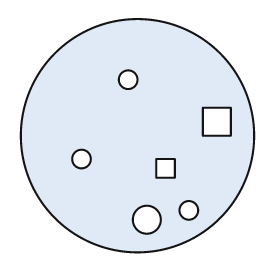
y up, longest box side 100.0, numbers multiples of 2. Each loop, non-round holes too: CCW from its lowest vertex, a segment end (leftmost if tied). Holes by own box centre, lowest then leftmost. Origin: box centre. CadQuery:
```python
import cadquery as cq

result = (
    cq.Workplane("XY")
    .moveTo(0.0, 0.0)
    .circle(50.0)
    .moveTo(4.0, -36.0)
    .circle(6.0)
    .moveTo(22.0, -32.0)
    .circle(4.0)
    .moveTo(8.0, -18.0)
    .lineTo(16.0, -18.0)
    .lineTo(16.0, -10.0)
    .lineTo(8.0, -10.0)
    .close()
    .moveTo(-24.0, -10.0)
    .circle(4.0)
    .moveTo(28.0, 0.0)
    .lineTo(40.0, 0.0)
    .lineTo(40.0, 12.0)
    .lineTo(28.0, 12.0)
    .close()
    .moveTo(-4.0, 24.0)
    .circle(4.0)
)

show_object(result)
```